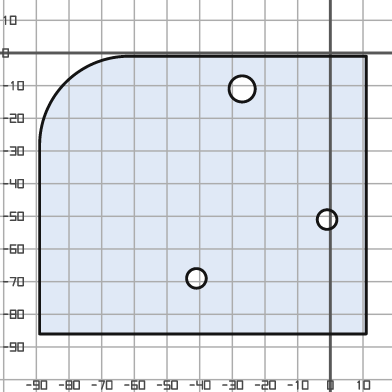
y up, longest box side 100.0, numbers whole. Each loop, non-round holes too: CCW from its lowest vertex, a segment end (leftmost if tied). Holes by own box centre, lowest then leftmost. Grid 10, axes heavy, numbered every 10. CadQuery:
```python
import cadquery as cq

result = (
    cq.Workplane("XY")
    .moveTo(-89.0, -86.0)
    .lineTo(11.0, -86.0)
    .lineTo(11.0, -1.0)
    .lineTo(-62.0, -1.0)
    .threePointArc((-81.0, -9.0), (-89.0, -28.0))
    .close()
    .moveTo(-41.0, -69.0)
    .circle(3.0)
    .moveTo(-1.0, -51.0)
    .circle(3.0)
    .moveTo(-27.0, -11.0)
    .circle(4.0)
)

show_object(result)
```